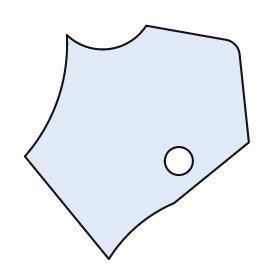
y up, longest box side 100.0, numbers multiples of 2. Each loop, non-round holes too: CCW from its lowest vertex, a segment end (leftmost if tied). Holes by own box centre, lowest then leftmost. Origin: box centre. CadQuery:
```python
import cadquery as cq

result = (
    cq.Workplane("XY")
    .moveTo(-12.0, -50.0)
    .threePointArc((0.0, -36.0), (16.0, -26.0))
    .lineTo(48.0, 0.0)
    .lineTo(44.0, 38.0)
    .threePointArc((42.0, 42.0), (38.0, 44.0))
    .lineTo(4.0, 50.0)
    .threePointArc((-12.0, 40.0), (-30.0, 46.0))
    .threePointArc((-34.0, 18.0), (-48.0, -6.0))
    .close()
    .moveTo(18.0, -8.0)
    .circle(6.0)
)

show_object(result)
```